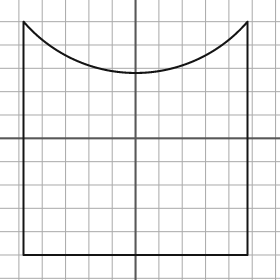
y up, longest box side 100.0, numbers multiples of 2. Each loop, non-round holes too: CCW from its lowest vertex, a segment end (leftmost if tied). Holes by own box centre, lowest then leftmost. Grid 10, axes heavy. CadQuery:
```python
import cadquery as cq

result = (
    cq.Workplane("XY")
    .moveTo(-48.0, -50.0)
    .lineTo(48.0, -50.0)
    .lineTo(48.0, 50.0)
    .threePointArc((0.0, 28.0), (-48.0, 50.0))
    .close()
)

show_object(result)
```